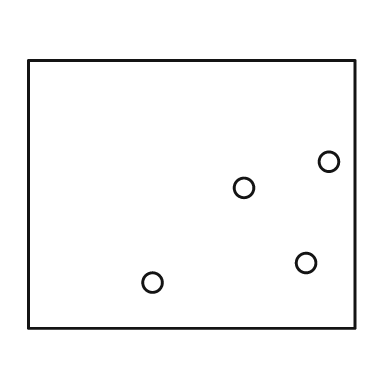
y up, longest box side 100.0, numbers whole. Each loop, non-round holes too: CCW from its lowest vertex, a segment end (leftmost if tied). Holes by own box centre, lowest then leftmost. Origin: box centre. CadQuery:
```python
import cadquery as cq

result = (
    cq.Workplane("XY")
    .moveTo(-50.0, -41.0)
    .lineTo(50.0, -41.0)
    .lineTo(50.0, 41.0)
    .lineTo(-50.0, 41.0)
    .close()
    .moveTo(-12.0, -27.0)
    .circle(3.0)
    .moveTo(35.0, -21.0)
    .circle(3.0)
    .moveTo(16.0, 2.0)
    .circle(3.0)
    .moveTo(42.0, 10.0)
    .circle(3.0)
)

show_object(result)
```